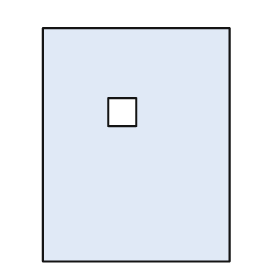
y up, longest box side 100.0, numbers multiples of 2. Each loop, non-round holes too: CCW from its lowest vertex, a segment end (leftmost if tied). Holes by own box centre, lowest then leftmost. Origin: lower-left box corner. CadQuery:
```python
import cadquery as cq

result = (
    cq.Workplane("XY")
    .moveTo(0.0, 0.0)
    .lineTo(80.0, 0.0)
    .lineTo(80.0, 100.0)
    .lineTo(0.0, 100.0)
    .close()
    .moveTo(28.0, 58.0)
    .lineTo(40.0, 58.0)
    .lineTo(40.0, 70.0)
    .lineTo(28.0, 70.0)
    .close()
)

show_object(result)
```